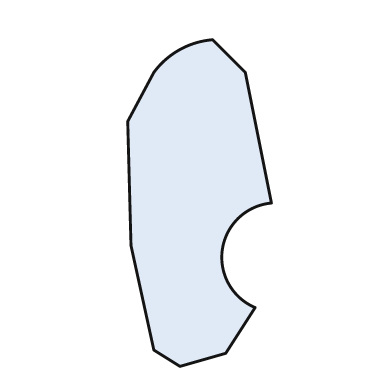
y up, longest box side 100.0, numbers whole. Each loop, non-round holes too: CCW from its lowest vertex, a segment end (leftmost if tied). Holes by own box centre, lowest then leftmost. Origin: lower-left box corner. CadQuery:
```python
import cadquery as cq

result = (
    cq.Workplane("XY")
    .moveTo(16.0, 0.0)
    .lineTo(30.0, 4.0)
    .lineTo(39.0, 18.0)
    .threePointArc((29.0, 36.0), (44.0, 50.0))
    .lineTo(36.0, 90.0)
    .lineTo(26.0, 100.0)
    .threePointArc((16.0, 97.0), (8.0, 90.0))
    .lineTo(0.0, 75.0)
    .lineTo(1.0, 37.0)
    .lineTo(8.0, 5.0)
    .close()
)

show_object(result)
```